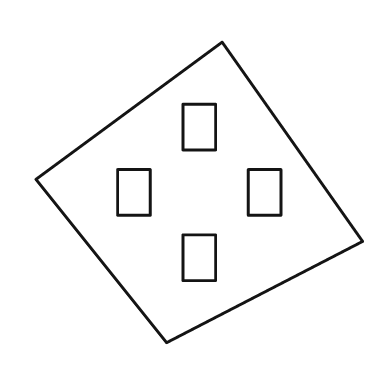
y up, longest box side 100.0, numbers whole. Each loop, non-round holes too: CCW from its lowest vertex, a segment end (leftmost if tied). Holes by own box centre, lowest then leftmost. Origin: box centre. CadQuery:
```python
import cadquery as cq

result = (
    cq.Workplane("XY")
    .moveTo(-10.0, -46.0)
    .lineTo(50.0, -15.0)
    .lineTo(7.0, 46.0)
    .lineTo(-50.0, 4.0)
    .close()
    .moveTo(-5.0, -27.0)
    .lineTo(5.0, -27.0)
    .lineTo(5.0, -13.0)
    .lineTo(-5.0, -13.0)
    .close()
    .moveTo(-25.0, -7.0)
    .lineTo(-15.0, -7.0)
    .lineTo(-15.0, 7.0)
    .lineTo(-25.0, 7.0)
    .close()
    .moveTo(15.0, -7.0)
    .lineTo(25.0, -7.0)
    .lineTo(25.0, 7.0)
    .lineTo(15.0, 7.0)
    .close()
    .moveTo(-5.0, 13.0)
    .lineTo(5.0, 13.0)
    .lineTo(5.0, 27.0)
    .lineTo(-5.0, 27.0)
    .close()
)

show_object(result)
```